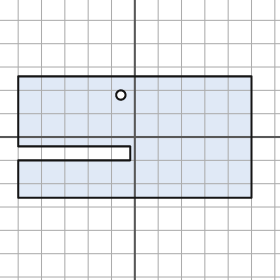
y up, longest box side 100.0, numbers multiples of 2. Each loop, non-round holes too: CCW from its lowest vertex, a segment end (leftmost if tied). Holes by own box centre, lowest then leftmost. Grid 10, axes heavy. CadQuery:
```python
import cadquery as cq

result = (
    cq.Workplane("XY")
    .moveTo(-50.0, -26.0)
    .lineTo(50.0, -26.0)
    .lineTo(50.0, 26.0)
    .lineTo(-50.0, 26.0)
    .lineTo(-50.0, -4.0)
    .lineTo(-2.0, -4.0)
    .lineTo(-2.0, -10.0)
    .lineTo(-50.0, -10.0)
    .close()
    .moveTo(-6.0, 18.0)
    .circle(2.0)
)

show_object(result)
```